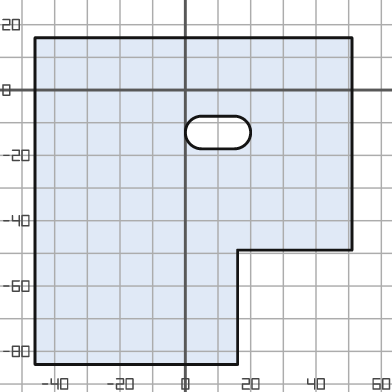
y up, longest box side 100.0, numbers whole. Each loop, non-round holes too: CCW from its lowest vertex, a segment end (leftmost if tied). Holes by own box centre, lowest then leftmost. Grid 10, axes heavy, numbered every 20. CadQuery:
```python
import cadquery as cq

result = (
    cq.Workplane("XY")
    .moveTo(-46.0, -84.0)
    .lineTo(16.0, -84.0)
    .lineTo(16.0, -49.0)
    .lineTo(51.0, -49.0)
    .lineTo(51.0, 16.0)
    .lineTo(-46.0, 16.0)
    .close()
    .moveTo(5.0, -18.0)
    .lineTo(15.0, -18.0)
    .threePointArc((20.0, -13.0), (15.0, -8.0))
    .lineTo(5.0, -8.0)
    .threePointArc((0.0, -13.0), (5.0, -18.0))
    .close()
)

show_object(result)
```